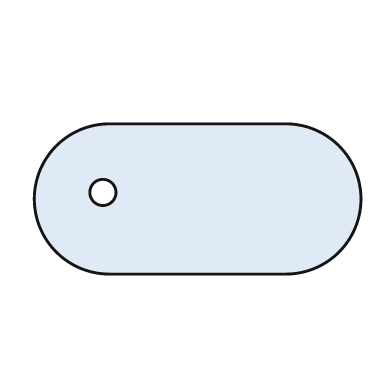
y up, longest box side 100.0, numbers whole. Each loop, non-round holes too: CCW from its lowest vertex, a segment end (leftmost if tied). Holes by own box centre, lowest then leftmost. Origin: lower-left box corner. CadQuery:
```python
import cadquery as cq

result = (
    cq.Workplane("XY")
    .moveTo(23.0, 0.0)
    .lineTo(77.0, 0.0)
    .threePointArc((100.0, 23.0), (77.0, 46.0))
    .lineTo(23.0, 46.0)
    .threePointArc((0.0, 23.0), (23.0, 0.0))
    .close()
    .moveTo(21.0, 25.0)
    .circle(4.0)
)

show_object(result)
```